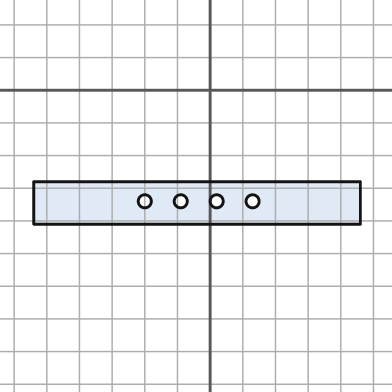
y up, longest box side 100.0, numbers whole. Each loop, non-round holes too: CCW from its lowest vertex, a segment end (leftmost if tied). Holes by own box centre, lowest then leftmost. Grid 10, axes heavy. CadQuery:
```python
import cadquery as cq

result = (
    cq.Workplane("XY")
    .moveTo(-54.0, -41.0)
    .lineTo(46.0, -41.0)
    .lineTo(46.0, -28.0)
    .lineTo(-54.0, -28.0)
    .close()
    .moveTo(-20.0, -34.0)
    .circle(2.0)
    .moveTo(-9.0, -34.0)
    .circle(2.0)
    .moveTo(2.0, -34.0)
    .circle(2.0)
    .moveTo(13.0, -34.0)
    .circle(2.0)
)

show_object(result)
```